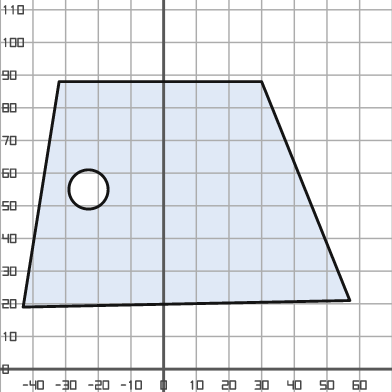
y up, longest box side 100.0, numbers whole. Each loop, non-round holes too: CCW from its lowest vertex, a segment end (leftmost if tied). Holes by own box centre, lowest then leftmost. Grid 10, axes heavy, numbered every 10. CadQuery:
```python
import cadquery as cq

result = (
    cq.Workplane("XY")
    .moveTo(-43.0, 19.0)
    .lineTo(57.0, 21.0)
    .lineTo(30.0, 88.0)
    .lineTo(-32.0, 88.0)
    .close()
    .moveTo(-23.0, 55.0)
    .circle(6.0)
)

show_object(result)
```